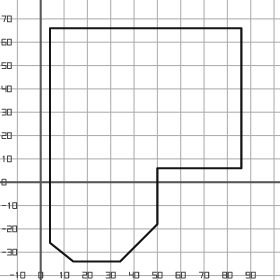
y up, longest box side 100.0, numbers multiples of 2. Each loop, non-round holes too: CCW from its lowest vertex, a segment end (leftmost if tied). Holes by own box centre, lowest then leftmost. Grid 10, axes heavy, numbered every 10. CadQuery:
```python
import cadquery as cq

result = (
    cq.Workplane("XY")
    .moveTo(14.0, -34.0)
    .lineTo(34.0, -34.0)
    .lineTo(50.0, -18.0)
    .lineTo(50.0, 6.0)
    .lineTo(86.0, 6.0)
    .lineTo(86.0, 66.0)
    .lineTo(4.0, 66.0)
    .lineTo(4.0, -26.0)
    .close()
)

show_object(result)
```